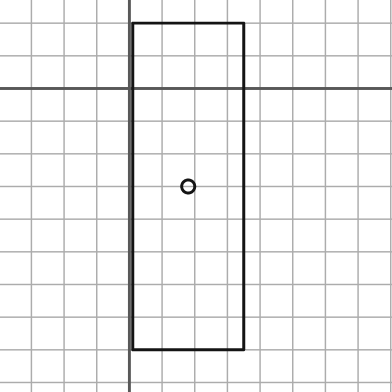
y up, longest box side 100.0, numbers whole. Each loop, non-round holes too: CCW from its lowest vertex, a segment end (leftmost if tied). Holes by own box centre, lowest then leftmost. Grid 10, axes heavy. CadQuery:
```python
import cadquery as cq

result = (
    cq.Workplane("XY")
    .moveTo(1.0, -80.0)
    .lineTo(35.0, -80.0)
    .lineTo(35.0, 20.0)
    .lineTo(1.0, 20.0)
    .close()
    .moveTo(18.0, -30.0)
    .circle(2.0)
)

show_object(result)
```